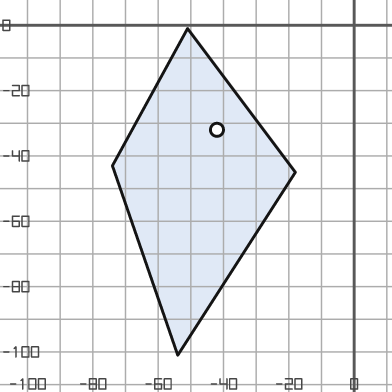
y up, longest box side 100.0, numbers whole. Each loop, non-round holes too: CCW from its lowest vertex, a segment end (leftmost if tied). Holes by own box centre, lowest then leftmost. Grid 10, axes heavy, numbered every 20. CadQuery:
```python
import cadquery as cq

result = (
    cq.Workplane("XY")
    .moveTo(-54.0, -101.0)
    .lineTo(-18.0, -45.0)
    .lineTo(-51.0, -1.0)
    .lineTo(-74.0, -43.0)
    .close()
    .moveTo(-42.0, -32.0)
    .circle(2.0)
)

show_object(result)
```